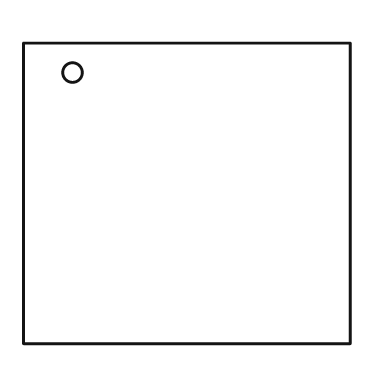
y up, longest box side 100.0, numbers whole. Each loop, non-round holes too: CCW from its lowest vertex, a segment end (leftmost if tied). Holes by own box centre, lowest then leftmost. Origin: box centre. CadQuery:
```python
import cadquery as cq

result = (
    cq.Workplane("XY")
    .moveTo(-50.0, -46.0)
    .lineTo(50.0, -46.0)
    .lineTo(50.0, 46.0)
    .lineTo(-50.0, 46.0)
    .close()
    .moveTo(-35.0, 37.0)
    .circle(3.0)
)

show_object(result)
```